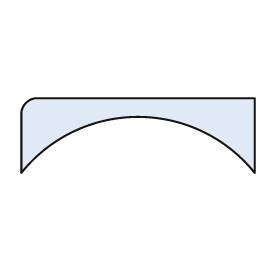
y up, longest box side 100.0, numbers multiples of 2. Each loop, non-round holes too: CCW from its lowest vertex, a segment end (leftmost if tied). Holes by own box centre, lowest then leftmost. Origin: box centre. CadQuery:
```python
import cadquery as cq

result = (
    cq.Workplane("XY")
    .moveTo(-50.0, -16.0)
    .threePointArc((0.0, 8.0), (50.0, -16.0))
    .lineTo(50.0, 16.0)
    .lineTo(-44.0, 16.0)
    .threePointArc((-48.0, 14.0), (-50.0, 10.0))
    .close()
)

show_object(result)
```